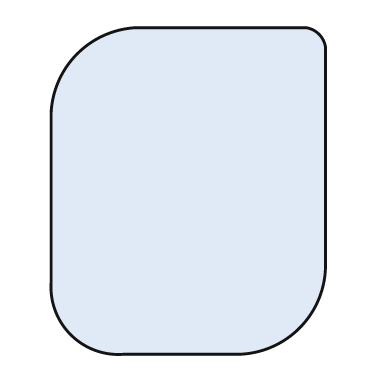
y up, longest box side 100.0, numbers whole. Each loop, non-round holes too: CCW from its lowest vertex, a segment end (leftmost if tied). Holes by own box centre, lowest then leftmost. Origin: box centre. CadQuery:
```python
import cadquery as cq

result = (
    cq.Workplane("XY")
    .moveTo(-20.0, -50.0)
    .lineTo(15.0, -50.0)
    .threePointArc((34.0, -42.0), (42.0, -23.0))
    .lineTo(42.0, 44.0)
    .threePointArc((40.0, 48.0), (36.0, 50.0))
    .lineTo(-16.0, 50.0)
    .threePointArc((-34.0, 42.0), (-42.0, 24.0))
    .lineTo(-42.0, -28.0)
    .threePointArc((-36.0, -44.0), (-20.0, -50.0))
    .close()
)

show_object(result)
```